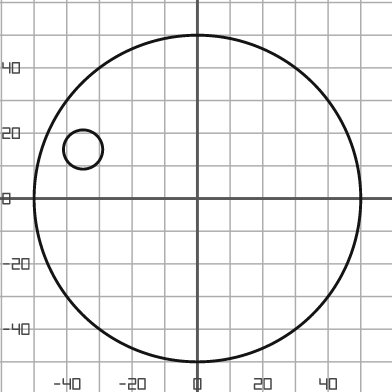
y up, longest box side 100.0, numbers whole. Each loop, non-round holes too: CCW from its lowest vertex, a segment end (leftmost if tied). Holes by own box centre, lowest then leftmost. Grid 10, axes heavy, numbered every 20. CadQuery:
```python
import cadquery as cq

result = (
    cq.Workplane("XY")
    .moveTo(0.0, 0.0)
    .circle(50.0)
    .moveTo(-35.0, 15.0)
    .circle(6.0)
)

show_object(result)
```